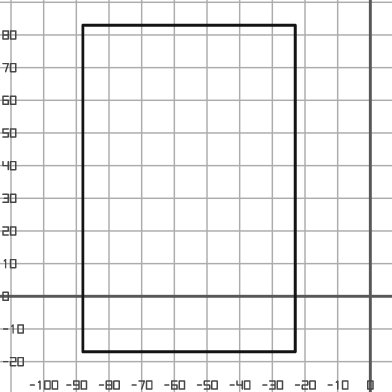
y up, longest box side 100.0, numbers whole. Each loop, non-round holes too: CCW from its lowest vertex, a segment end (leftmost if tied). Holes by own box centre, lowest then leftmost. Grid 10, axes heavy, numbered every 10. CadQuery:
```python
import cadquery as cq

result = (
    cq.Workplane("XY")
    .moveTo(-88.0, -17.0)
    .lineTo(-23.0, -17.0)
    .lineTo(-23.0, 83.0)
    .lineTo(-88.0, 83.0)
    .close()
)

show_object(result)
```